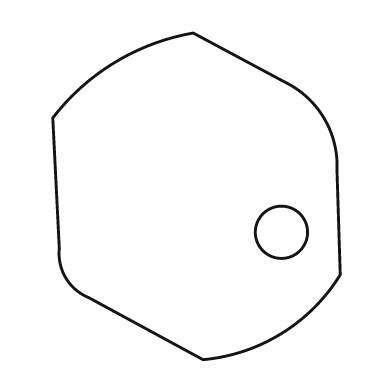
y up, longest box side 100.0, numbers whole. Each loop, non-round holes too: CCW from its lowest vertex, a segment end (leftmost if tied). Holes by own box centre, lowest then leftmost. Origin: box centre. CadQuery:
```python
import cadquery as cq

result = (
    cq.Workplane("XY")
    .moveTo(2.0, -50.0)
    .threePointArc((26.0, -42.0), (44.0, -24.0))
    .lineTo(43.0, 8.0)
    .threePointArc((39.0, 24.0), (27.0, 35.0))
    .lineTo(-1.0, 50.0)
    .threePointArc((-25.0, 41.0), (-44.0, 24.0))
    .lineTo(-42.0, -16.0)
    .threePointArc((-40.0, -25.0), (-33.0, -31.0))
    .close()
    .moveTo(26.0, -11.0)
    .circle(8.0)
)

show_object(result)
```